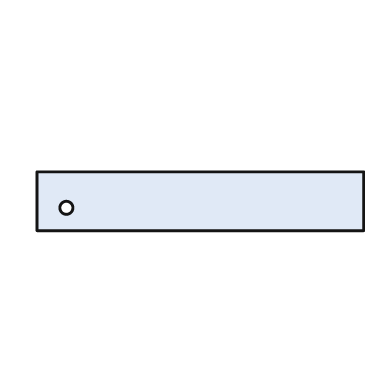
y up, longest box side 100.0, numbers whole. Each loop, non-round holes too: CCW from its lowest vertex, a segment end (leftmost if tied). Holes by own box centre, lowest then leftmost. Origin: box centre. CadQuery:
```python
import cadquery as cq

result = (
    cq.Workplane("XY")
    .moveTo(-50.0, -9.0)
    .lineTo(50.0, -9.0)
    .lineTo(50.0, 9.0)
    .lineTo(-50.0, 9.0)
    .close()
    .moveTo(-41.0, -2.0)
    .circle(2.0)
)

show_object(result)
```